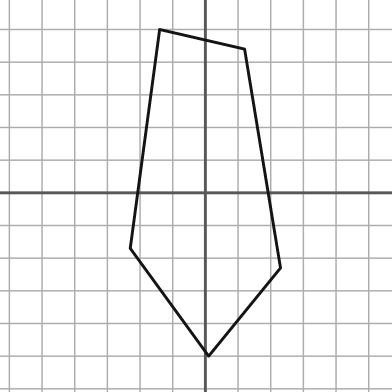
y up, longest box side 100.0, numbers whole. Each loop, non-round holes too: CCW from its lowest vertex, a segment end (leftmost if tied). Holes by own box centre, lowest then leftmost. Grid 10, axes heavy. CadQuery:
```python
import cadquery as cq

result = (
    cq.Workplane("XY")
    .moveTo(1.0, -50.0)
    .lineTo(23.0, -23.0)
    .lineTo(12.0, 44.0)
    .lineTo(-14.0, 50.0)
    .lineTo(-23.0, -17.0)
    .close()
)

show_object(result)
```